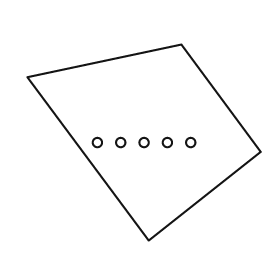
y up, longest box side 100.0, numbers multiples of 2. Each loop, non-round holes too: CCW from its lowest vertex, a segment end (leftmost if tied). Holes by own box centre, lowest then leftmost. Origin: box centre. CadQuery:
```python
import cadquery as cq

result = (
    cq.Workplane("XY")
    .moveTo(2.0, -42.0)
    .lineTo(50.0, -4.0)
    .lineTo(16.0, 42.0)
    .lineTo(-50.0, 28.0)
    .close()
    .moveTo(-20.0, 0.0)
    .circle(2.0)
    .moveTo(-10.0, 0.0)
    .circle(2.0)
    .moveTo(0.0, 0.0)
    .circle(2.0)
    .moveTo(10.0, 0.0)
    .circle(2.0)
    .moveTo(20.0, 0.0)
    .circle(2.0)
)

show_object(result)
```